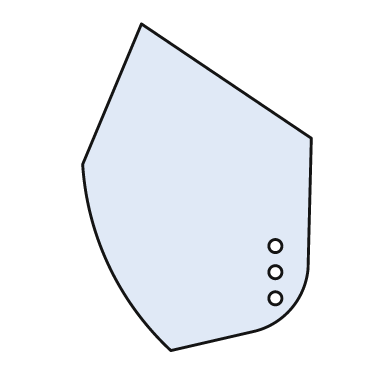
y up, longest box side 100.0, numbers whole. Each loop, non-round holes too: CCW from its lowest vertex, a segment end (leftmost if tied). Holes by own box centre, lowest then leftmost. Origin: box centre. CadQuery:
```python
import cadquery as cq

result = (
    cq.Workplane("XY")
    .moveTo(-8.0, -50.0)
    .lineTo(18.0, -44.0)
    .threePointArc((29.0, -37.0), (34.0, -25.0))
    .lineTo(35.0, 15.0)
    .lineTo(-17.0, 50.0)
    .lineTo(-35.0, 7.0)
    .threePointArc((-27.0, -24.0), (-8.0, -50.0))
    .close()
    .moveTo(24.0, -34.0)
    .circle(2.0)
    .moveTo(24.0, -26.0)
    .circle(2.0)
    .moveTo(24.0, -18.0)
    .circle(2.0)
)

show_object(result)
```